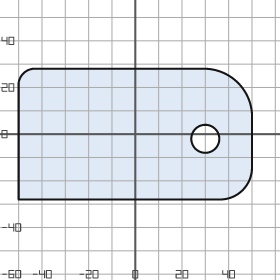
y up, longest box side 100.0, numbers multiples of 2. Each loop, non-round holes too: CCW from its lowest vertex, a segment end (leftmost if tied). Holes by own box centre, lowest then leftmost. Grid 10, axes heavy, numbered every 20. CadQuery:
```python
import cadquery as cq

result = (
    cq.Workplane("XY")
    .moveTo(-50.0, -28.0)
    .lineTo(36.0, -28.0)
    .threePointArc((46.0, -24.0), (50.0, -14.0))
    .lineTo(50.0, 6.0)
    .threePointArc((44.0, 22.0), (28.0, 28.0))
    .lineTo(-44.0, 28.0)
    .threePointArc((-48.0, 26.0), (-50.0, 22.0))
    .close()
    .moveTo(30.0, -2.0)
    .circle(6.0)
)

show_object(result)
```